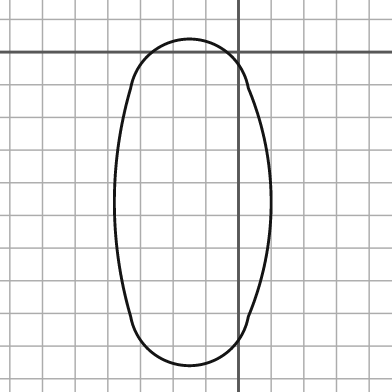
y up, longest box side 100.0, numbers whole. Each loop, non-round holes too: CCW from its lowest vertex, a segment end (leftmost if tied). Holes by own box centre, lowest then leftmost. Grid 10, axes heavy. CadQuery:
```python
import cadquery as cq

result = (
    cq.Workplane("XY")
    .moveTo(-33.0, -81.0)
    .threePointArc((-15.0, -96.0), (3.0, -81.0))
    .threePointArc((10.0, -46.0), (3.0, -11.0))
    .threePointArc((-15.0, 4.0), (-33.0, -11.0))
    .threePointArc((-38.0, -46.0), (-33.0, -81.0))
    .close()
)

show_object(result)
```